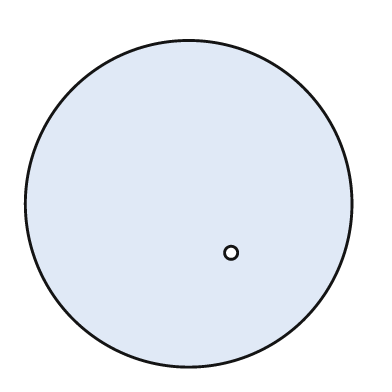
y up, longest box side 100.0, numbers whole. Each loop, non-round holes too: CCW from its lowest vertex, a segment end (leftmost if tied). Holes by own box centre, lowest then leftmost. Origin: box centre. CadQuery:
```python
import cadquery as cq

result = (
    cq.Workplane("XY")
    .moveTo(0.0, 0.0)
    .circle(50.0)
    .moveTo(13.0, -15.0)
    .circle(2.0)
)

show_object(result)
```